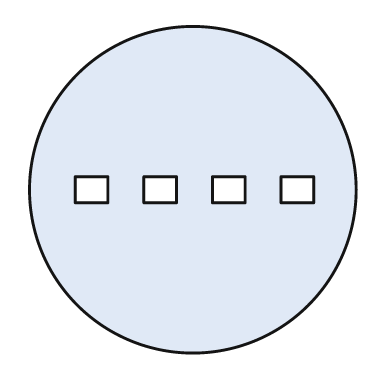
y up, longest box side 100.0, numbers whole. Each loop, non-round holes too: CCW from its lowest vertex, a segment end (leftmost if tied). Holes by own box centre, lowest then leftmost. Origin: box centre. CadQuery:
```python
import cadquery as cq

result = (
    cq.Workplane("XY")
    .moveTo(0.0, 0.0)
    .circle(50.0)
    .moveTo(-36.0, -4.0)
    .lineTo(-26.0, -4.0)
    .lineTo(-26.0, 4.0)
    .lineTo(-36.0, 4.0)
    .close()
    .moveTo(-15.0, -4.0)
    .lineTo(-5.0, -4.0)
    .lineTo(-5.0, 4.0)
    .lineTo(-15.0, 4.0)
    .close()
    .moveTo(6.0, -4.0)
    .lineTo(16.0, -4.0)
    .lineTo(16.0, 4.0)
    .lineTo(6.0, 4.0)
    .close()
    .moveTo(27.0, -4.0)
    .lineTo(37.0, -4.0)
    .lineTo(37.0, 4.0)
    .lineTo(27.0, 4.0)
    .close()
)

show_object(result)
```